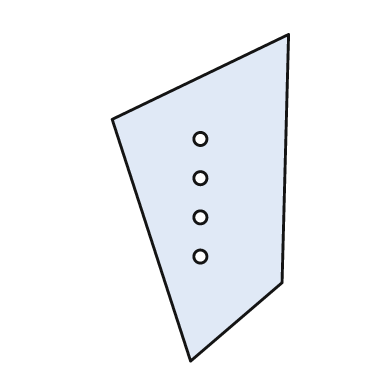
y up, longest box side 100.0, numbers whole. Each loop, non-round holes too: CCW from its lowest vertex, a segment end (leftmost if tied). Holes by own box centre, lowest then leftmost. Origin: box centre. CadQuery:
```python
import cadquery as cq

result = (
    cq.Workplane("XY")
    .moveTo(-3.0, -50.0)
    .lineTo(25.0, -26.0)
    .lineTo(27.0, 50.0)
    .lineTo(-27.0, 24.0)
    .close()
    .moveTo(0.0, -18.0)
    .circle(2.0)
    .moveTo(0.0, -6.0)
    .circle(2.0)
    .moveTo(0.0, 6.0)
    .circle(2.0)
    .moveTo(0.0, 18.0)
    .circle(2.0)
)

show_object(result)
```